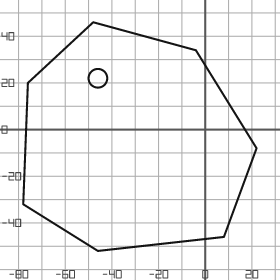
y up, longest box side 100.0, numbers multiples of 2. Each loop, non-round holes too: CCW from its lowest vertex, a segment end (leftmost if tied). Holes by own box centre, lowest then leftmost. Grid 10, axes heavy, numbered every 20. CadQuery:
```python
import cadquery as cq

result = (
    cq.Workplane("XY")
    .moveTo(-46.0, -52.0)
    .lineTo(8.0, -46.0)
    .lineTo(22.0, -8.0)
    .lineTo(-4.0, 34.0)
    .lineTo(-48.0, 46.0)
    .lineTo(-76.0, 20.0)
    .lineTo(-78.0, -32.0)
    .close()
    .moveTo(-46.0, 22.0)
    .circle(4.0)
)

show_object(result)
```